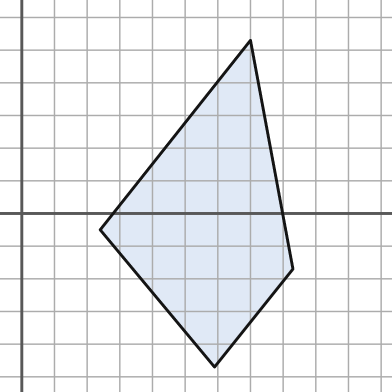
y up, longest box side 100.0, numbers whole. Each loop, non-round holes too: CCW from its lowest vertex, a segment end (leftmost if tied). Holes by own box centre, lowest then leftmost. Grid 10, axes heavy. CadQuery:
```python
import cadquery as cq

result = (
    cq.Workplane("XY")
    .moveTo(59.0, -47.0)
    .lineTo(83.0, -17.0)
    .lineTo(70.0, 53.0)
    .lineTo(24.0, -5.0)
    .close()
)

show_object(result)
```